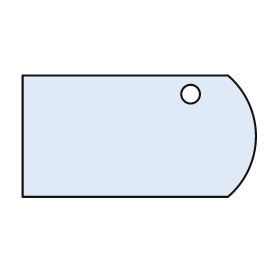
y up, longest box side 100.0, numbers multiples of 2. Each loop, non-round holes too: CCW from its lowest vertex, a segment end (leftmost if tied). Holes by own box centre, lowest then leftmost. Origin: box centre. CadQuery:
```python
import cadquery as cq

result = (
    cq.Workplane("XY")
    .moveTo(-50.0, -26.0)
    .lineTo(38.0, -26.0)
    .threePointArc((50.0, 0.0), (38.0, 26.0))
    .lineTo(-50.0, 26.0)
    .close()
    .moveTo(22.0, 18.0)
    .circle(4.0)
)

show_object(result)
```